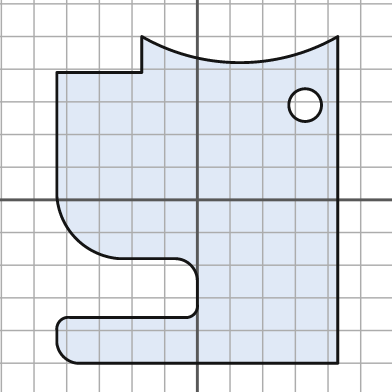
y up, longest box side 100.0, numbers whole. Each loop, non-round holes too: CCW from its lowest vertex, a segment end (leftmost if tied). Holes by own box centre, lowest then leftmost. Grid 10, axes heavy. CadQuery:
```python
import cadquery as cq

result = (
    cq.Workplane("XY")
    .moveTo(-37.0, -50.0)
    .lineTo(43.0, -50.0)
    .lineTo(43.0, 50.0)
    .threePointArc((13.0, 42.0), (-17.0, 50.0))
    .lineTo(-17.0, 39.0)
    .lineTo(-43.0, 39.0)
    .lineTo(-43.0, 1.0)
    .threePointArc((-37.0, -12.0), (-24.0, -18.0))
    .lineTo(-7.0, -18.0)
    .threePointArc((-2.0, -20.0), (0.0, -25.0))
    .lineTo(0.0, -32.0)
    .threePointArc((-1.0, -35.0), (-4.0, -36.0))
    .lineTo(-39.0, -36.0)
    .threePointArc((-42.0, -37.0), (-43.0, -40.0))
    .lineTo(-43.0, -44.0)
    .threePointArc((-41.0, -48.0), (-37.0, -50.0))
    .close()
    .moveTo(33.0, 29.0)
    .circle(5.0)
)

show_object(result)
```